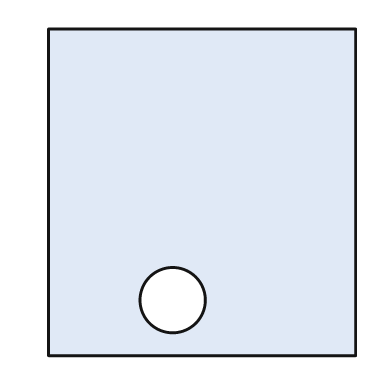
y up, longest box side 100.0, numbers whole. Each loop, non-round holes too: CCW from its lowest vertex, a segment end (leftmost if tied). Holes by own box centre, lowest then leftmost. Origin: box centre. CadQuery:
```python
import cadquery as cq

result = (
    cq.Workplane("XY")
    .moveTo(-47.0, -50.0)
    .lineTo(47.0, -50.0)
    .lineTo(47.0, 50.0)
    .lineTo(-47.0, 50.0)
    .close()
    .moveTo(-9.0, -33.0)
    .circle(10.0)
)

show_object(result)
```